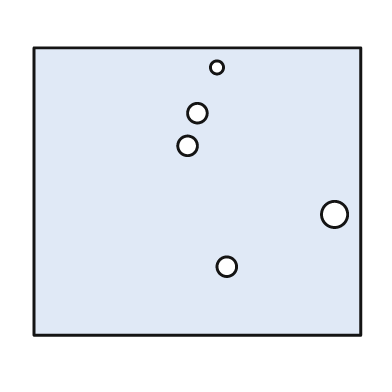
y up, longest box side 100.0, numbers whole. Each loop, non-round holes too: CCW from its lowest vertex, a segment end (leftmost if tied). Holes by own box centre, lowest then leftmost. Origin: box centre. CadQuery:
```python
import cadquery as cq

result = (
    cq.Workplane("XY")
    .moveTo(-50.0, -44.0)
    .lineTo(50.0, -44.0)
    .lineTo(50.0, 44.0)
    .lineTo(-50.0, 44.0)
    .close()
    .moveTo(9.0, -23.0)
    .circle(3.0)
    .moveTo(42.0, -7.0)
    .circle(4.0)
    .moveTo(-3.0, 14.0)
    .circle(3.0)
    .moveTo(0.0, 24.0)
    .circle(3.0)
    .moveTo(6.0, 38.0)
    .circle(2.0)
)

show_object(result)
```